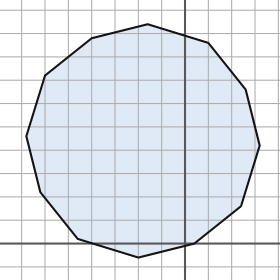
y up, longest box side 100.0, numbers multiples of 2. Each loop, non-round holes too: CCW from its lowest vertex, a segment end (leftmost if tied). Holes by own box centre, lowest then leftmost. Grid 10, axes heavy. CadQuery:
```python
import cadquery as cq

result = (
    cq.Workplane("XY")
    .moveTo(-20.0, -6.0)
    .lineTo(4.0, 0.0)
    .lineTo(24.0, 16.0)
    .lineTo(32.0, 42.0)
    .lineTo(26.0, 66.0)
    .lineTo(10.0, 86.0)
    .lineTo(-16.0, 94.0)
    .lineTo(-40.0, 88.0)
    .lineTo(-60.0, 72.0)
    .lineTo(-68.0, 46.0)
    .lineTo(-62.0, 22.0)
    .lineTo(-46.0, 2.0)
    .close()
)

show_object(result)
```